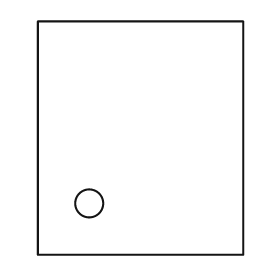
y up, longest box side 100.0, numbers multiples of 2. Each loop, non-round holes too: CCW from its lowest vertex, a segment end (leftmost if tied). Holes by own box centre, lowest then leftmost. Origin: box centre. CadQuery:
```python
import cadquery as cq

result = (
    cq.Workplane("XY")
    .moveTo(-44.0, -50.0)
    .lineTo(44.0, -50.0)
    .lineTo(44.0, 50.0)
    .lineTo(-44.0, 50.0)
    .close()
    .moveTo(-22.0, -28.0)
    .circle(6.0)
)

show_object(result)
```